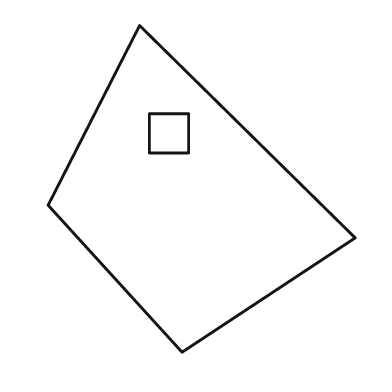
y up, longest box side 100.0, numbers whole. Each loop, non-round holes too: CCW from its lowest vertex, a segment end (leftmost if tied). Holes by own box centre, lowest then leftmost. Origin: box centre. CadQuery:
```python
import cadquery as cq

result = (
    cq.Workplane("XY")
    .moveTo(-6.0, -50.0)
    .lineTo(47.0, -15.0)
    .lineTo(-19.0, 50.0)
    .lineTo(-47.0, -5.0)
    .close()
    .moveTo(-16.0, 11.0)
    .lineTo(-4.0, 11.0)
    .lineTo(-4.0, 23.0)
    .lineTo(-16.0, 23.0)
    .close()
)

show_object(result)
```